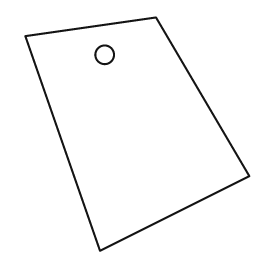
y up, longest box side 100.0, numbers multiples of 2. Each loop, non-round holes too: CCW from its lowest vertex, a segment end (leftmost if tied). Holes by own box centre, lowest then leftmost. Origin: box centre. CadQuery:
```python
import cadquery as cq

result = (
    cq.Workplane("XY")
    .moveTo(-16.0, -50.0)
    .lineTo(48.0, -18.0)
    .lineTo(8.0, 50.0)
    .lineTo(-48.0, 42.0)
    .close()
    .moveTo(-14.0, 34.0)
    .circle(4.0)
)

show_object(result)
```